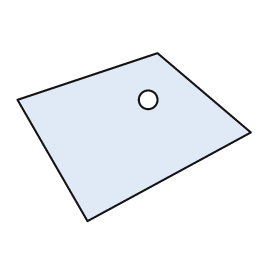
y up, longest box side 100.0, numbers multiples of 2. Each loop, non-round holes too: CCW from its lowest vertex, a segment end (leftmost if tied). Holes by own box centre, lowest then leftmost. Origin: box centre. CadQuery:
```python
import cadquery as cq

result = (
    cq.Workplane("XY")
    .moveTo(-20.0, -36.0)
    .lineTo(50.0, 2.0)
    .lineTo(10.0, 36.0)
    .lineTo(-50.0, 16.0)
    .close()
    .moveTo(6.0, 16.0)
    .circle(4.0)
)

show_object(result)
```